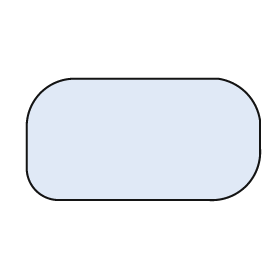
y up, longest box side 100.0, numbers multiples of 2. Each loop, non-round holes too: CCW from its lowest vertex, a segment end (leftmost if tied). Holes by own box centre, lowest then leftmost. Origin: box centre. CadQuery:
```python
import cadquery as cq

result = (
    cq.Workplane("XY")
    .moveTo(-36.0, -26.0)
    .lineTo(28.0, -26.0)
    .threePointArc((44.0, -20.0), (50.0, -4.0))
    .lineTo(50.0, 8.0)
    .threePointArc((44.0, 20.0), (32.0, 26.0))
    .lineTo(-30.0, 26.0)
    .threePointArc((-44.0, 20.0), (-50.0, 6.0))
    .lineTo(-50.0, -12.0)
    .threePointArc((-46.0, -22.0), (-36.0, -26.0))
    .close()
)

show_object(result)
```